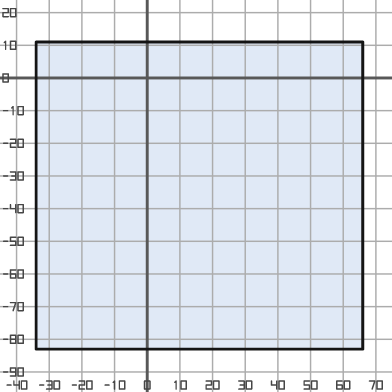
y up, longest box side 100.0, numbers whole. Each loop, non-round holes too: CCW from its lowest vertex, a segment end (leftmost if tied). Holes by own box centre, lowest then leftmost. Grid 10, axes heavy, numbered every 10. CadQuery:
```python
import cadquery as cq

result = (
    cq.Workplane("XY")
    .moveTo(-34.0, -83.0)
    .lineTo(66.0, -83.0)
    .lineTo(66.0, 11.0)
    .lineTo(-34.0, 11.0)
    .close()
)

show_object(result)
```